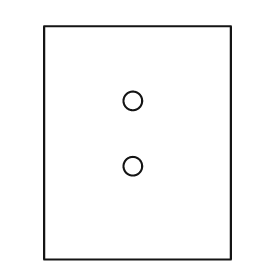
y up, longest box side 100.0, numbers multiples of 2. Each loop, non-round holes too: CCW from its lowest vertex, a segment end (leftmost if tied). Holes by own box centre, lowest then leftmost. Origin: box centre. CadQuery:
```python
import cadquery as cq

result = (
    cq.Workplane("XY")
    .moveTo(-40.0, -50.0)
    .lineTo(40.0, -50.0)
    .lineTo(40.0, 50.0)
    .lineTo(-40.0, 50.0)
    .close()
    .moveTo(-2.0, -10.0)
    .circle(4.0)
    .moveTo(-2.0, 18.0)
    .circle(4.0)
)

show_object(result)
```